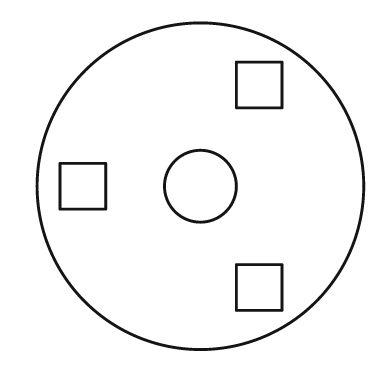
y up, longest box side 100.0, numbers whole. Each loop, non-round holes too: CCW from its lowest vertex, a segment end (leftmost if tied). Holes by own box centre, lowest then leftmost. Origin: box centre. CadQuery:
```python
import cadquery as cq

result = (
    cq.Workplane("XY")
    .moveTo(0.0, 0.0)
    .circle(50.0)
    .moveTo(11.0, -38.0)
    .lineTo(25.0, -38.0)
    .lineTo(25.0, -24.0)
    .lineTo(11.0, -24.0)
    .close()
    .moveTo(-43.0, -7.0)
    .lineTo(-29.0, -7.0)
    .lineTo(-29.0, 7.0)
    .lineTo(-43.0, 7.0)
    .close()
    .moveTo(0.0, 0.0)
    .circle(11.0)
    .moveTo(11.0, 24.0)
    .lineTo(25.0, 24.0)
    .lineTo(25.0, 38.0)
    .lineTo(11.0, 38.0)
    .close()
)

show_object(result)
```